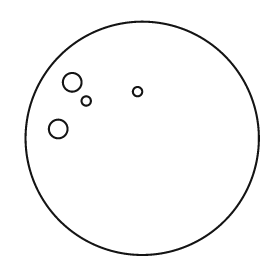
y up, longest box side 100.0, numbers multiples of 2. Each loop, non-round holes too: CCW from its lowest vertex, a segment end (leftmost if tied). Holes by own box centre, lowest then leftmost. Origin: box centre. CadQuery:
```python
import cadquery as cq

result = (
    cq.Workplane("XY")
    .moveTo(0.0, 0.0)
    .circle(50.0)
    .moveTo(-36.0, 4.0)
    .circle(4.0)
    .moveTo(-24.0, 16.0)
    .circle(2.0)
    .moveTo(-2.0, 20.0)
    .circle(2.0)
    .moveTo(-30.0, 24.0)
    .circle(4.0)
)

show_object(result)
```